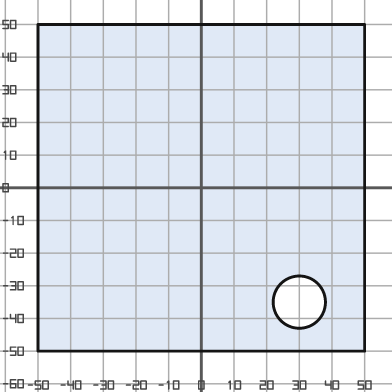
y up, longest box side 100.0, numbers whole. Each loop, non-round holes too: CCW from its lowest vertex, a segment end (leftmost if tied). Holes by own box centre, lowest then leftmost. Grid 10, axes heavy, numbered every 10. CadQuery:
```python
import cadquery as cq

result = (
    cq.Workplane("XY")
    .moveTo(-50.0, -50.0)
    .lineTo(50.0, -50.0)
    .lineTo(50.0, 50.0)
    .lineTo(-50.0, 50.0)
    .close()
    .moveTo(30.0, -35.0)
    .circle(8.0)
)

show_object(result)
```